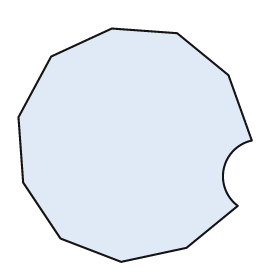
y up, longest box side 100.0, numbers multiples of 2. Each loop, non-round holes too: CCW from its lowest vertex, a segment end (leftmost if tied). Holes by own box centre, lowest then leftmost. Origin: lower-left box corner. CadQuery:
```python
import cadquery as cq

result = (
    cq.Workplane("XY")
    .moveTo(44.0, 0.0)
    .lineTo(72.0, 6.0)
    .lineTo(94.0, 24.0)
    .threePointArc((88.0, 40.0), (100.0, 52.0))
    .lineTo(90.0, 80.0)
    .lineTo(68.0, 98.0)
    .lineTo(40.0, 100.0)
    .lineTo(14.0, 88.0)
    .lineTo(0.0, 62.0)
    .lineTo(2.0, 34.0)
    .lineTo(18.0, 10.0)
    .close()
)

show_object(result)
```